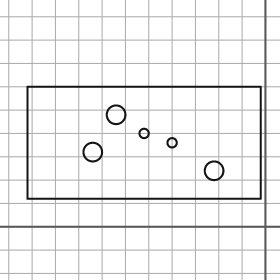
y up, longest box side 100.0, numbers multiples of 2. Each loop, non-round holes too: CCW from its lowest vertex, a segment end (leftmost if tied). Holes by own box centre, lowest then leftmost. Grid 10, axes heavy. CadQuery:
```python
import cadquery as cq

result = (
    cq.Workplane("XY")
    .moveTo(-102.0, 12.0)
    .lineTo(-2.0, 12.0)
    .lineTo(-2.0, 60.0)
    .lineTo(-102.0, 60.0)
    .close()
    .moveTo(-22.0, 24.0)
    .circle(4.0)
    .moveTo(-74.0, 32.0)
    .circle(4.0)
    .moveTo(-40.0, 36.0)
    .circle(2.0)
    .moveTo(-52.0, 40.0)
    .circle(2.0)
    .moveTo(-64.0, 48.0)
    .circle(4.0)
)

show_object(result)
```